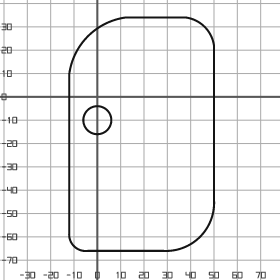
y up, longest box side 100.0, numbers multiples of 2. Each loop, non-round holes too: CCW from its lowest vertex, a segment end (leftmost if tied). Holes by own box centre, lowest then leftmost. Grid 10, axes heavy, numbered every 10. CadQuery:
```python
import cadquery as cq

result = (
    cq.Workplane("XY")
    .moveTo(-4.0, -66.0)
    .lineTo(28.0, -66.0)
    .threePointArc((44.0, -60.0), (50.0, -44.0))
    .lineTo(50.0, 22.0)
    .threePointArc((46.0, 30.0), (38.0, 34.0))
    .lineTo(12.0, 34.0)
    .threePointArc((-4.0, 26.0), (-12.0, 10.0))
    .lineTo(-12.0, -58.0)
    .threePointArc((-10.0, -64.0), (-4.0, -66.0))
    .close()
    .moveTo(0.0, -10.0)
    .circle(6.0)
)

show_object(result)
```